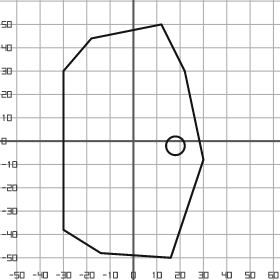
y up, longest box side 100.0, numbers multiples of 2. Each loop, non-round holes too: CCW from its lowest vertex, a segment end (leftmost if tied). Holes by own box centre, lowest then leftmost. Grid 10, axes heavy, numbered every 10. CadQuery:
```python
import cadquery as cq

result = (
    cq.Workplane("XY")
    .moveTo(16.0, -50.0)
    .lineTo(30.0, -8.0)
    .lineTo(22.0, 30.0)
    .lineTo(12.0, 50.0)
    .lineTo(-18.0, 44.0)
    .lineTo(-30.0, 30.0)
    .lineTo(-30.0, -38.0)
    .lineTo(-14.0, -48.0)
    .close()
    .moveTo(18.0, -2.0)
    .circle(4.0)
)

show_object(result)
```